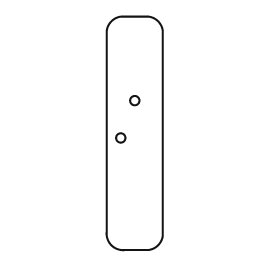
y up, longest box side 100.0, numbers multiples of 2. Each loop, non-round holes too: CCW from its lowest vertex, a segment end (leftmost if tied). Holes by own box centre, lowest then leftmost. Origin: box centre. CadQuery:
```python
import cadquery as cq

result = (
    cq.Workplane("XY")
    .moveTo(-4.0, -50.0)
    .lineTo(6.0, -50.0)
    .threePointArc((10.0, -48.0), (12.0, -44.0))
    .lineTo(12.0, 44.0)
    .threePointArc((10.0, 48.0), (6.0, 50.0))
    .lineTo(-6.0, 50.0)
    .threePointArc((-10.0, 48.0), (-12.0, 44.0))
    .lineTo(-12.0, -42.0)
    .threePointArc((-10.0, -48.0), (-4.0, -50.0))
    .close()
    .moveTo(-6.0, -2.0)
    .circle(2.0)
    .moveTo(0.0, 14.0)
    .circle(2.0)
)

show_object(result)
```